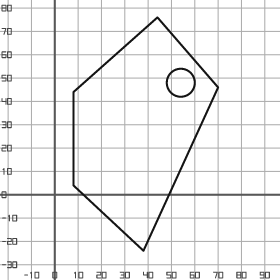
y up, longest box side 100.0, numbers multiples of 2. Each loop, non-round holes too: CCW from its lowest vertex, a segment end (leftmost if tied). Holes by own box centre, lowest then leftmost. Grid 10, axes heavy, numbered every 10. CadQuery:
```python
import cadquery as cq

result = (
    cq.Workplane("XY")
    .moveTo(38.0, -24.0)
    .lineTo(70.0, 46.0)
    .lineTo(44.0, 76.0)
    .lineTo(8.0, 44.0)
    .lineTo(8.0, 4.0)
    .close()
    .moveTo(54.0, 48.0)
    .circle(6.0)
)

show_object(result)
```